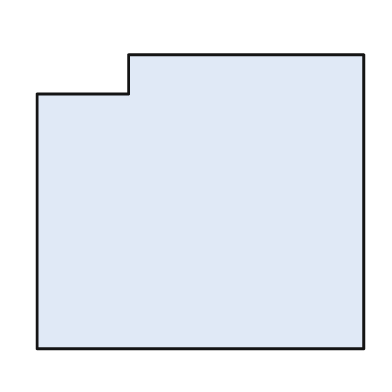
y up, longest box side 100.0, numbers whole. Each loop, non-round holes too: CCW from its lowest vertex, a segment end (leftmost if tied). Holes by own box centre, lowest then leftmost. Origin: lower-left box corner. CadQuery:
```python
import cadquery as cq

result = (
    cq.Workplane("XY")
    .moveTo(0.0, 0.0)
    .lineTo(100.0, 0.0)
    .lineTo(100.0, 90.0)
    .lineTo(28.0, 90.0)
    .lineTo(28.0, 78.0)
    .lineTo(0.0, 78.0)
    .close()
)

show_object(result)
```